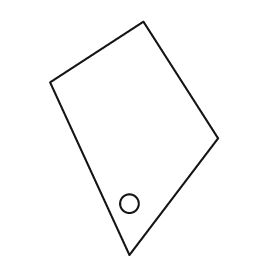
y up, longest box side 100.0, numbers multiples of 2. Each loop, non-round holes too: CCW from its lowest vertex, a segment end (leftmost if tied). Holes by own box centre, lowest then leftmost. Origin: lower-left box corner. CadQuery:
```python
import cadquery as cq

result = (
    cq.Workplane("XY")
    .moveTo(34.0, 0.0)
    .lineTo(72.0, 50.0)
    .lineTo(40.0, 100.0)
    .lineTo(0.0, 74.0)
    .close()
    .moveTo(34.0, 22.0)
    .circle(4.0)
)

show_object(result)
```